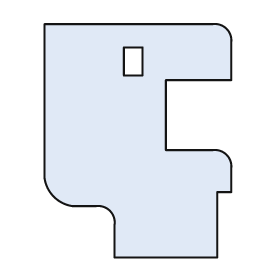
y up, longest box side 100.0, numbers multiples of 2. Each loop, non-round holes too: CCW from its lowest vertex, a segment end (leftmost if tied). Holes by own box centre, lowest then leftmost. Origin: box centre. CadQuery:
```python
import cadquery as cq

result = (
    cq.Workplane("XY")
    .moveTo(-10.0, -50.0)
    .lineTo(34.0, -50.0)
    .lineTo(34.0, -22.0)
    .lineTo(40.0, -22.0)
    .lineTo(40.0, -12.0)
    .threePointArc((38.0, -6.0), (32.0, -4.0))
    .lineTo(12.0, -4.0)
    .lineTo(12.0, 26.0)
    .lineTo(40.0, 26.0)
    .lineTo(40.0, 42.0)
    .threePointArc((38.0, 48.0), (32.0, 50.0))
    .lineTo(-40.0, 50.0)
    .lineTo(-40.0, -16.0)
    .threePointArc((-36.0, -24.0), (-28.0, -28.0))
    .lineTo(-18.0, -28.0)
    .threePointArc((-12.0, -30.0), (-10.0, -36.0))
    .close()
    .moveTo(-6.0, 28.0)
    .lineTo(2.0, 28.0)
    .lineTo(2.0, 40.0)
    .lineTo(-6.0, 40.0)
    .close()
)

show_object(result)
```